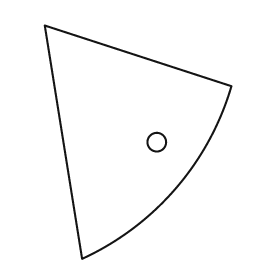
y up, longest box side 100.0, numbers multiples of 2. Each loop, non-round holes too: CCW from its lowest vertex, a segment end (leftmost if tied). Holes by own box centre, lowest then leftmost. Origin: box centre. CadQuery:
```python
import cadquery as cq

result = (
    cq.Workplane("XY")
    .moveTo(-24.0, -50.0)
    .threePointArc((16.0, -20.0), (40.0, 24.0))
    .lineTo(-40.0, 50.0)
    .close()
    .moveTo(8.0, 0.0)
    .circle(4.0)
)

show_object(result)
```